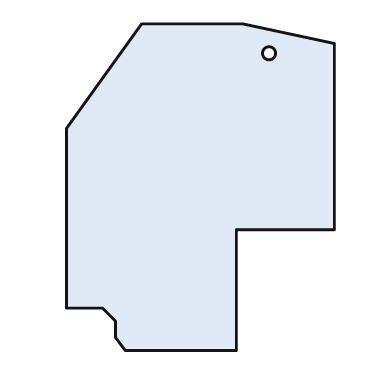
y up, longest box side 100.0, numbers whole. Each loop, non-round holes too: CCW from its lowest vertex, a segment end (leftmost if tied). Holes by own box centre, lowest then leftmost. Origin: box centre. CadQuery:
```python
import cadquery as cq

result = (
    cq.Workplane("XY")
    .moveTo(-23.0, -50.0)
    .lineTo(11.0, -50.0)
    .lineTo(11.0, -13.0)
    .lineTo(41.0, -13.0)
    .lineTo(41.0, 44.0)
    .lineTo(13.0, 50.0)
    .lineTo(-18.0, 50.0)
    .lineTo(-41.0, 18.0)
    .lineTo(-41.0, -37.0)
    .lineTo(-30.0, -37.0)
    .lineTo(-26.0, -41.0)
    .lineTo(-26.0, -46.0)
    .close()
    .moveTo(21.0, 41.0)
    .circle(2.0)
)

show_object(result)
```